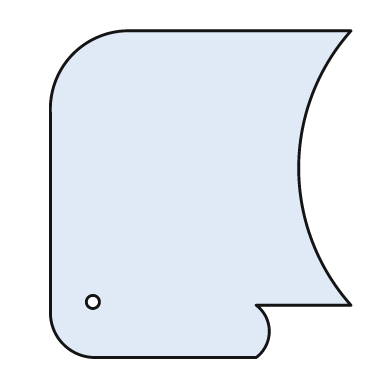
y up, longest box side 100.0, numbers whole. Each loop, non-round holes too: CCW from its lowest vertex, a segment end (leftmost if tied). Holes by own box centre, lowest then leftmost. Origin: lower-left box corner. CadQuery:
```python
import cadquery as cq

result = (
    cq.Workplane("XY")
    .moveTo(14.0, 0.0)
    .lineTo(63.0, 0.0)
    .threePointArc((67.0, 8.0), (63.0, 16.0))
    .lineTo(92.0, 16.0)
    .threePointArc((76.0, 58.0), (92.0, 100.0))
    .lineTo(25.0, 100.0)
    .threePointArc((7.0, 93.0), (0.0, 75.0))
    .lineTo(0.0, 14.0)
    .threePointArc((4.0, 4.0), (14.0, 0.0))
    .close()
    .moveTo(13.0, 17.0)
    .circle(2.0)
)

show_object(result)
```